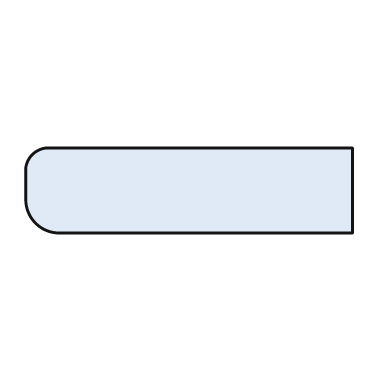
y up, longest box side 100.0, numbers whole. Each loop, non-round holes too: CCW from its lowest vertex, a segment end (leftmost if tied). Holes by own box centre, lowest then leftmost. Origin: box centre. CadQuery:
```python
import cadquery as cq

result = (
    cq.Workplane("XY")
    .moveTo(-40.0, -13.0)
    .lineTo(50.0, -13.0)
    .lineTo(50.0, 13.0)
    .lineTo(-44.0, 13.0)
    .threePointArc((-48.0, 11.0), (-50.0, 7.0))
    .lineTo(-50.0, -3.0)
    .threePointArc((-47.0, -10.0), (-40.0, -13.0))
    .close()
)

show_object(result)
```